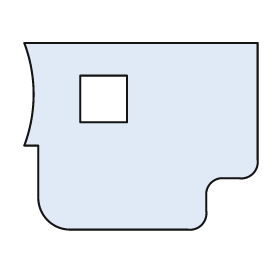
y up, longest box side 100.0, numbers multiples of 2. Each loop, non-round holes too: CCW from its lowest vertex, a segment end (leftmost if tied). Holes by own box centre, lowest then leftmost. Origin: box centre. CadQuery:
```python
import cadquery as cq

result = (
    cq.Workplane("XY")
    .moveTo(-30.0, -40.0)
    .lineTo(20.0, -40.0)
    .threePointArc((26.0, -38.0), (28.0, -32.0))
    .lineTo(28.0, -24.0)
    .threePointArc((30.0, -20.0), (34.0, -18.0))
    .lineTo(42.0, -18.0)
    .threePointArc((48.0, -16.0), (50.0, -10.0))
    .lineTo(50.0, 40.0)
    .lineTo(-50.0, 40.0)
    .threePointArc((-46.0, 18.0), (-50.0, -4.0))
    .lineTo(-44.0, -4.0)
    .lineTo(-44.0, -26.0)
    .threePointArc((-40.0, -36.0), (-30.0, -40.0))
    .close()
    .moveTo(-26.0, 6.0)
    .lineTo(-6.0, 6.0)
    .lineTo(-6.0, 26.0)
    .lineTo(-26.0, 26.0)
    .close()
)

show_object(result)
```